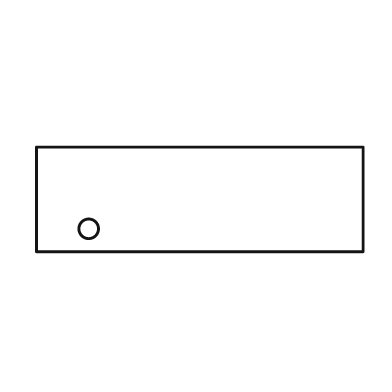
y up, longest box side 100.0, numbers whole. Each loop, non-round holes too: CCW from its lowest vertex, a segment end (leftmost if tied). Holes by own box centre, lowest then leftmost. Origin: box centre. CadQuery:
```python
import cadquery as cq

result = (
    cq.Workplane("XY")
    .moveTo(-50.0, -16.0)
    .lineTo(50.0, -16.0)
    .lineTo(50.0, 16.0)
    .lineTo(-50.0, 16.0)
    .close()
    .moveTo(-34.0, -9.0)
    .circle(3.0)
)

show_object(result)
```